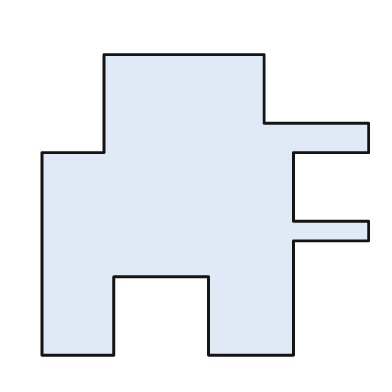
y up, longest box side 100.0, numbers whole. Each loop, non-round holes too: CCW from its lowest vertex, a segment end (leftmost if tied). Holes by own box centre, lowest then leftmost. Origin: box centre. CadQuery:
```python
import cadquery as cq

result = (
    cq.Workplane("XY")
    .moveTo(-50.0, -46.0)
    .lineTo(-28.0, -46.0)
    .lineTo(-28.0, -22.0)
    .lineTo(1.0, -22.0)
    .lineTo(1.0, -46.0)
    .lineTo(27.0, -46.0)
    .lineTo(27.0, -11.0)
    .lineTo(50.0, -11.0)
    .lineTo(50.0, -5.0)
    .lineTo(27.0, -5.0)
    .lineTo(27.0, 16.0)
    .lineTo(50.0, 16.0)
    .lineTo(50.0, 25.0)
    .lineTo(18.0, 25.0)
    .lineTo(18.0, 46.0)
    .lineTo(-31.0, 46.0)
    .lineTo(-31.0, 16.0)
    .lineTo(-50.0, 16.0)
    .close()
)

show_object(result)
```